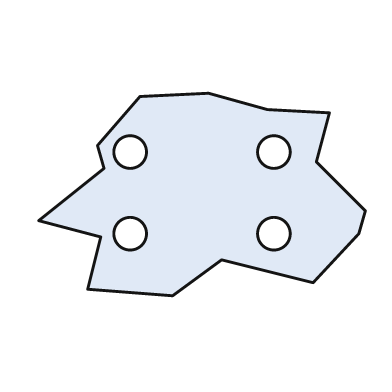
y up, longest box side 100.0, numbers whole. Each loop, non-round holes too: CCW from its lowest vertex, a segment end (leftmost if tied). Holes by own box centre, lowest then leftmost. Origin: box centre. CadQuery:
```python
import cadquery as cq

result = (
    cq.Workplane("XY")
    .moveTo(-9.0, -31.0)
    .lineTo(6.0, -20.0)
    .lineTo(34.0, -27.0)
    .lineTo(48.0, -12.0)
    .lineTo(50.0, -5.0)
    .lineTo(35.0, 10.0)
    .lineTo(39.0, 25.0)
    .lineTo(20.0, 26.0)
    .lineTo(2.0, 31.0)
    .lineTo(-19.0, 30.0)
    .lineTo(-32.0, 15.0)
    .lineTo(-30.0, 8.0)
    .lineTo(-50.0, -8.0)
    .lineTo(-31.0, -13.0)
    .lineTo(-35.0, -29.0)
    .close()
    .moveTo(-22.0, -12.0)
    .circle(5.0)
    .moveTo(22.0, -12.0)
    .circle(5.0)
    .moveTo(-22.0, 13.0)
    .circle(5.0)
    .moveTo(22.0, 13.0)
    .circle(5.0)
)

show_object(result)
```